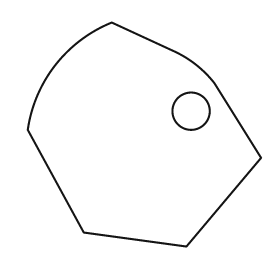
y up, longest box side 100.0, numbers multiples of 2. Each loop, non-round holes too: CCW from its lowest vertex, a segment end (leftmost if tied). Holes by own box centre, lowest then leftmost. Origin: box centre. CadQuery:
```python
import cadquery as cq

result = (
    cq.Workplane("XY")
    .moveTo(18.0, -48.0)
    .lineTo(50.0, -10.0)
    .lineTo(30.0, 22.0)
    .threePointArc((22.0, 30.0), (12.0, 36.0))
    .lineTo(-14.0, 48.0)
    .threePointArc((-38.0, 30.0), (-50.0, 2.0))
    .lineTo(-26.0, -42.0)
    .close()
    .moveTo(20.0, 10.0)
    .circle(8.0)
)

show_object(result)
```